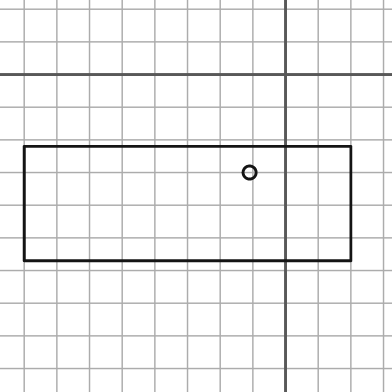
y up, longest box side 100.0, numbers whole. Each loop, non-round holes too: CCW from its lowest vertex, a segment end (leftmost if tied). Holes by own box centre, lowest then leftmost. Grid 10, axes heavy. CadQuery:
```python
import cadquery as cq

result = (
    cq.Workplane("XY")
    .moveTo(-80.0, -57.0)
    .lineTo(20.0, -57.0)
    .lineTo(20.0, -22.0)
    .lineTo(-80.0, -22.0)
    .close()
    .moveTo(-11.0, -30.0)
    .circle(2.0)
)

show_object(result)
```